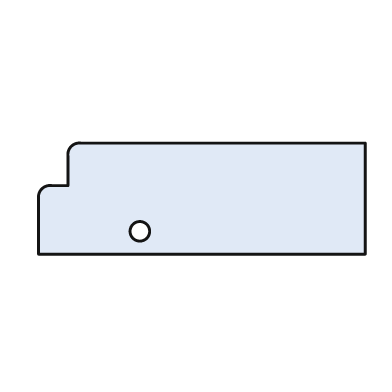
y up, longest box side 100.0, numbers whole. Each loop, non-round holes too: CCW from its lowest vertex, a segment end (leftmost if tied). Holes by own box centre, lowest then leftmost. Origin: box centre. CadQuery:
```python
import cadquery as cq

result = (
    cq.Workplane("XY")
    .moveTo(-50.0, -17.0)
    .lineTo(50.0, -17.0)
    .lineTo(50.0, 17.0)
    .lineTo(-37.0, 17.0)
    .threePointArc((-40.0, 16.0), (-41.0, 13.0))
    .lineTo(-41.0, 4.0)
    .lineTo(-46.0, 4.0)
    .threePointArc((-49.0, 3.0), (-50.0, 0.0))
    .close()
    .moveTo(-19.0, -10.0)
    .circle(3.0)
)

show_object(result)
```